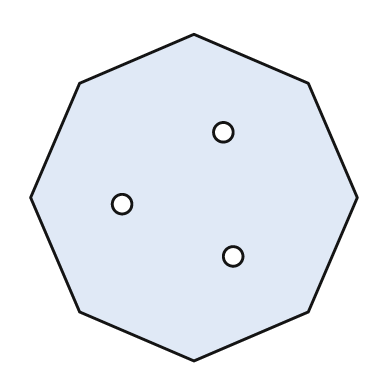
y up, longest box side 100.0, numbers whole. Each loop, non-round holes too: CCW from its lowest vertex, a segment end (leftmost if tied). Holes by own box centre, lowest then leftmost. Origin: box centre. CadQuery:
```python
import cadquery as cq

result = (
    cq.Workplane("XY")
    .moveTo(0.0, -50.0)
    .lineTo(35.0, -35.0)
    .lineTo(50.0, 0.0)
    .lineTo(35.0, 35.0)
    .lineTo(0.0, 50.0)
    .lineTo(-35.0, 35.0)
    .lineTo(-50.0, 0.0)
    .lineTo(-35.0, -35.0)
    .close()
    .moveTo(12.0, -18.0)
    .circle(3.0)
    .moveTo(-22.0, -2.0)
    .circle(3.0)
    .moveTo(9.0, 20.0)
    .circle(3.0)
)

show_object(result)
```